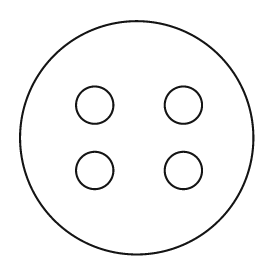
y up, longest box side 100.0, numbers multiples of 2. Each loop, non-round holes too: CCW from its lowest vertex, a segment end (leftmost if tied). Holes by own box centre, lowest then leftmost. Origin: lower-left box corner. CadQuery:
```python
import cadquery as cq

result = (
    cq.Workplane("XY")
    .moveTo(50.0, 50.0)
    .circle(50.0)
    .moveTo(32.0, 36.0)
    .circle(8.0)
    .moveTo(70.0, 36.0)
    .circle(8.0)
    .moveTo(32.0, 64.0)
    .circle(8.0)
    .moveTo(70.0, 64.0)
    .circle(8.0)
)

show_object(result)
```